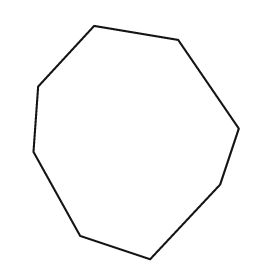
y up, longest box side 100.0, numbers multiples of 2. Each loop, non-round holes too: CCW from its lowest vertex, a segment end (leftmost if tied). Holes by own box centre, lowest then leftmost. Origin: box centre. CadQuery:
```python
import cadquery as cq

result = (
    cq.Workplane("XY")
    .moveTo(6.0, -50.0)
    .lineTo(36.0, -18.0)
    .lineTo(44.0, 6.0)
    .lineTo(18.0, 44.0)
    .lineTo(-18.0, 50.0)
    .lineTo(-42.0, 24.0)
    .lineTo(-44.0, -4.0)
    .lineTo(-24.0, -40.0)
    .close()
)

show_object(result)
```